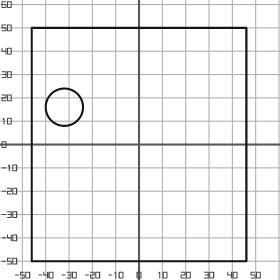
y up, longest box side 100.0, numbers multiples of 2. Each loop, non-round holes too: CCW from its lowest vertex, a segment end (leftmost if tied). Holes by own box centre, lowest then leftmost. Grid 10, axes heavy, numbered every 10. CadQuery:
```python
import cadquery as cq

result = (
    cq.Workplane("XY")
    .moveTo(-46.0, -50.0)
    .lineTo(46.0, -50.0)
    .lineTo(46.0, 50.0)
    .lineTo(-46.0, 50.0)
    .close()
    .moveTo(-32.0, 16.0)
    .circle(8.0)
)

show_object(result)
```